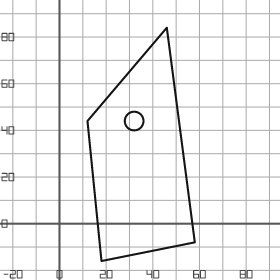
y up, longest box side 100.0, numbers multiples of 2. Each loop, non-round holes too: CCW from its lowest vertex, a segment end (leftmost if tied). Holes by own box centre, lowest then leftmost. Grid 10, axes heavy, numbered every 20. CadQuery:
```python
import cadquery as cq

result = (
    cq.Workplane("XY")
    .moveTo(18.0, -16.0)
    .lineTo(58.0, -8.0)
    .lineTo(46.0, 84.0)
    .lineTo(12.0, 44.0)
    .close()
    .moveTo(32.0, 44.0)
    .circle(4.0)
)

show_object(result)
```